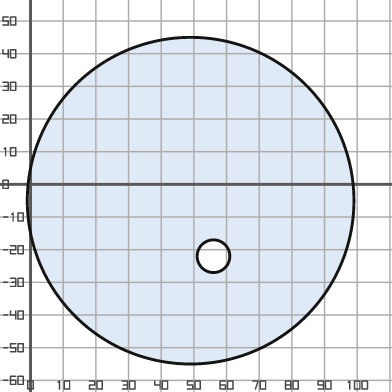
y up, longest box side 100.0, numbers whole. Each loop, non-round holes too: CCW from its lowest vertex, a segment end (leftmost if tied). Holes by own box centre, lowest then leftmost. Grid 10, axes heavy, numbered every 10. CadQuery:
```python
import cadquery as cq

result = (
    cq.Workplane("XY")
    .moveTo(49.0, -5.0)
    .circle(50.0)
    .moveTo(56.0, -22.0)
    .circle(5.0)
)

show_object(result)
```